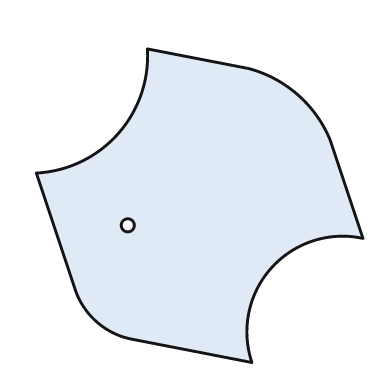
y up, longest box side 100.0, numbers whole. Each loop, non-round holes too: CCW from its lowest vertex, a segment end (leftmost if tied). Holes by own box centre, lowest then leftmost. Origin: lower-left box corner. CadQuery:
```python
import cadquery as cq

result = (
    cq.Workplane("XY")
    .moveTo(66.0, 0.0)
    .threePointArc((72.0, 29.0), (100.0, 38.0))
    .lineTo(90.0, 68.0)
    .threePointArc((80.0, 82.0), (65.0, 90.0))
    .lineTo(34.0, 96.0)
    .threePointArc((25.0, 70.0), (0.0, 58.0))
    .lineTo(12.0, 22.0)
    .threePointArc((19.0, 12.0), (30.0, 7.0))
    .close()
    .moveTo(28.0, 42.0)
    .circle(2.0)
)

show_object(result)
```